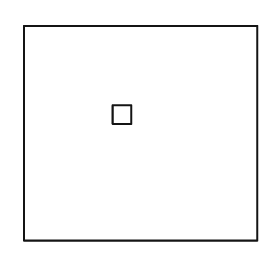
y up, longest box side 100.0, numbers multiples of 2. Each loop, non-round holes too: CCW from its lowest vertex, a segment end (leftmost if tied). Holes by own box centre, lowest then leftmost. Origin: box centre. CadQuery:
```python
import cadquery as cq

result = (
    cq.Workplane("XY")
    .moveTo(-50.0, -46.0)
    .lineTo(50.0, -46.0)
    .lineTo(50.0, 46.0)
    .lineTo(-50.0, 46.0)
    .close()
    .moveTo(-12.0, 4.0)
    .lineTo(-4.0, 4.0)
    .lineTo(-4.0, 12.0)
    .lineTo(-12.0, 12.0)
    .close()
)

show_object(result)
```